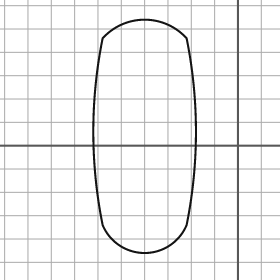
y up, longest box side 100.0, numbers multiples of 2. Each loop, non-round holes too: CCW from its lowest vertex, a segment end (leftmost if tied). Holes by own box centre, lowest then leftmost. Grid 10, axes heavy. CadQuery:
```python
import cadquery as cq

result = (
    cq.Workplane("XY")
    .moveTo(-58.0, -34.0)
    .threePointArc((-40.0, -46.0), (-22.0, -34.0))
    .threePointArc((-18.0, 6.0), (-22.0, 46.0))
    .threePointArc((-40.0, 54.0), (-58.0, 46.0))
    .threePointArc((-62.0, 6.0), (-58.0, -34.0))
    .close()
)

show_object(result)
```